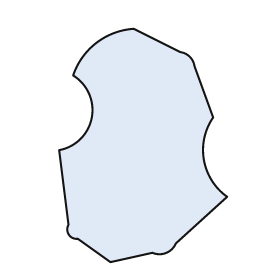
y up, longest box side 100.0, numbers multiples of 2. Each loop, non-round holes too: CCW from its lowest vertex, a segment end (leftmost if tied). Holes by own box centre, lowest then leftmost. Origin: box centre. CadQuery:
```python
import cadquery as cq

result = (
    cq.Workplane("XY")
    .moveTo(-14.0, -50.0)
    .lineTo(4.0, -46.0)
    .threePointArc((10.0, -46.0), (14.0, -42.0))
    .lineTo(36.0, -22.0)
    .threePointArc((26.0, -6.0), (30.0, 12.0))
    .lineTo(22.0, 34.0)
    .threePointArc((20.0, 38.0), (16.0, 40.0))
    .lineTo(-4.0, 50.0)
    .threePointArc((-20.0, 44.0), (-30.0, 30.0))
    .threePointArc((-22.0, 12.0), (-36.0, -2.0))
    .lineTo(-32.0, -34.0)
    .threePointArc((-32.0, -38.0), (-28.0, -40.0))
    .close()
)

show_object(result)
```